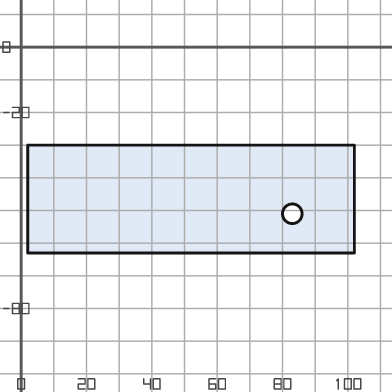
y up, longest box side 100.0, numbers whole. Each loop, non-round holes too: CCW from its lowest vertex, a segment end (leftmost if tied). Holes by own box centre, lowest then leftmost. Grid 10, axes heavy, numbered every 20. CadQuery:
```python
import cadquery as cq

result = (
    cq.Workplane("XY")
    .moveTo(2.0, -63.0)
    .lineTo(102.0, -63.0)
    .lineTo(102.0, -30.0)
    .lineTo(2.0, -30.0)
    .close()
    .moveTo(83.0, -51.0)
    .circle(3.0)
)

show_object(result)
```